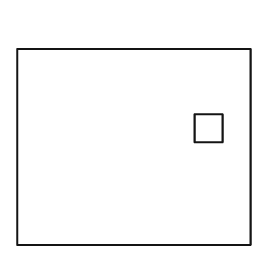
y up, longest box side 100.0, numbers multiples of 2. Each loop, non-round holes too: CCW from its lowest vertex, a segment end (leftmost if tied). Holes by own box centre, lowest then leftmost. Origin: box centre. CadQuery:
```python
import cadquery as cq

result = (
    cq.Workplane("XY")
    .moveTo(-50.0, -42.0)
    .lineTo(50.0, -42.0)
    .lineTo(50.0, 42.0)
    .lineTo(-50.0, 42.0)
    .close()
    .moveTo(26.0, 2.0)
    .lineTo(38.0, 2.0)
    .lineTo(38.0, 14.0)
    .lineTo(26.0, 14.0)
    .close()
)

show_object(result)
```